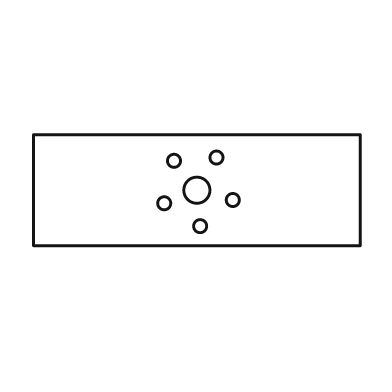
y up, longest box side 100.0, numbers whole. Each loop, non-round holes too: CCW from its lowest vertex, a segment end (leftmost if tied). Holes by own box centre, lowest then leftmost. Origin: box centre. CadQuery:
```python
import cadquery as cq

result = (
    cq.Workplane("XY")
    .moveTo(-50.0, -17.0)
    .lineTo(50.0, -17.0)
    .lineTo(50.0, 17.0)
    .lineTo(-50.0, 17.0)
    .close()
    .moveTo(1.0, -11.0)
    .circle(2.0)
    .moveTo(-10.0, -4.0)
    .circle(2.0)
    .moveTo(11.0, -3.0)
    .circle(2.0)
    .moveTo(0.0, 0.0)
    .circle(4.0)
    .moveTo(-7.0, 9.0)
    .circle(2.0)
    .moveTo(6.0, 10.0)
    .circle(2.0)
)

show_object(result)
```